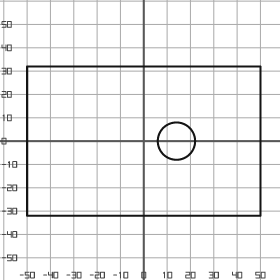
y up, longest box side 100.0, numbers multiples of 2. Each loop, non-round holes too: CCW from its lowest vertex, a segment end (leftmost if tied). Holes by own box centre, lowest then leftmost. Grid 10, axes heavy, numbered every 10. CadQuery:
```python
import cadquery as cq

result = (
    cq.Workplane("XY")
    .moveTo(-50.0, -32.0)
    .lineTo(50.0, -32.0)
    .lineTo(50.0, 32.0)
    .lineTo(-50.0, 32.0)
    .close()
    .moveTo(14.0, 0.0)
    .circle(8.0)
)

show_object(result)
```